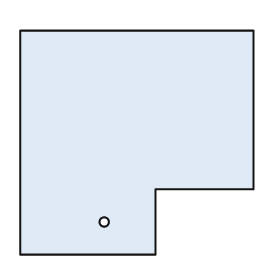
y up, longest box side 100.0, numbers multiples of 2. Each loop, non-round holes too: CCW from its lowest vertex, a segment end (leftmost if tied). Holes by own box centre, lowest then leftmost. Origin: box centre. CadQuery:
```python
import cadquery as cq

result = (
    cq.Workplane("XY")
    .moveTo(-50.0, -48.0)
    .lineTo(8.0, -48.0)
    .lineTo(8.0, -20.0)
    .lineTo(50.0, -20.0)
    .lineTo(50.0, 48.0)
    .lineTo(-50.0, 48.0)
    .close()
    .moveTo(-14.0, -34.0)
    .circle(2.0)
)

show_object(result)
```